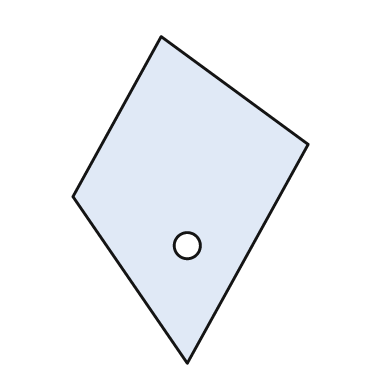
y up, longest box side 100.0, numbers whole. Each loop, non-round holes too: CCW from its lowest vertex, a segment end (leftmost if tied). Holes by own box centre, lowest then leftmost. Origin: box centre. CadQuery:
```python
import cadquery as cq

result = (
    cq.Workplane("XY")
    .moveTo(-1.0, -50.0)
    .lineTo(36.0, 17.0)
    .lineTo(-9.0, 50.0)
    .lineTo(-36.0, 1.0)
    .close()
    .moveTo(-1.0, -14.0)
    .circle(4.0)
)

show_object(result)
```